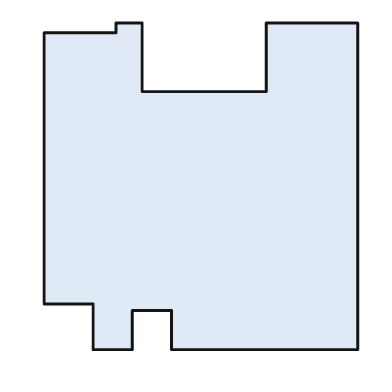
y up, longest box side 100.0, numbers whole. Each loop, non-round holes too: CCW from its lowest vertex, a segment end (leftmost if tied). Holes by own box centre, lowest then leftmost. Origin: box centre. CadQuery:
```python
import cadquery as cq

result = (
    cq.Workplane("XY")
    .moveTo(-33.0, -50.0)
    .lineTo(-21.0, -50.0)
    .lineTo(-21.0, -38.0)
    .lineTo(-9.0, -38.0)
    .lineTo(-9.0, -50.0)
    .lineTo(48.0, -50.0)
    .lineTo(48.0, 50.0)
    .lineTo(20.0, 50.0)
    .lineTo(20.0, 29.0)
    .lineTo(-18.0, 29.0)
    .lineTo(-18.0, 50.0)
    .lineTo(-26.0, 50.0)
    .lineTo(-26.0, 47.0)
    .lineTo(-48.0, 47.0)
    .lineTo(-48.0, -36.0)
    .lineTo(-33.0, -36.0)
    .close()
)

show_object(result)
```